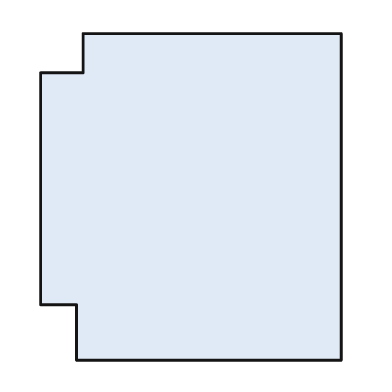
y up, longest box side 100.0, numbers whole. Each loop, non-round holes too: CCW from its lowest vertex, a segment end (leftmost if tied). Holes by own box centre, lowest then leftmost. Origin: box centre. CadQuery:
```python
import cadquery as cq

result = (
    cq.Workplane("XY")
    .moveTo(-35.0, -50.0)
    .lineTo(46.0, -50.0)
    .lineTo(46.0, 50.0)
    .lineTo(-33.0, 50.0)
    .lineTo(-33.0, 38.0)
    .lineTo(-46.0, 38.0)
    .lineTo(-46.0, -33.0)
    .lineTo(-35.0, -33.0)
    .close()
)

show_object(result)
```